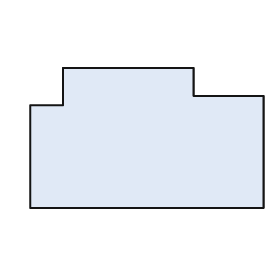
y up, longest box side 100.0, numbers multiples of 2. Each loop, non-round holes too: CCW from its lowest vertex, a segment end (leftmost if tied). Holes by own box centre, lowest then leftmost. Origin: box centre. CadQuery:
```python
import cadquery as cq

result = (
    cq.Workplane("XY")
    .moveTo(-50.0, -30.0)
    .lineTo(50.0, -30.0)
    .lineTo(50.0, 18.0)
    .lineTo(20.0, 18.0)
    .lineTo(20.0, 30.0)
    .lineTo(-36.0, 30.0)
    .lineTo(-36.0, 14.0)
    .lineTo(-50.0, 14.0)
    .close()
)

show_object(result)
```